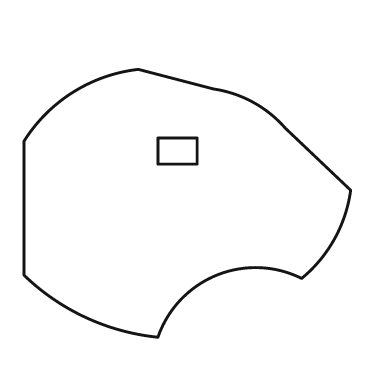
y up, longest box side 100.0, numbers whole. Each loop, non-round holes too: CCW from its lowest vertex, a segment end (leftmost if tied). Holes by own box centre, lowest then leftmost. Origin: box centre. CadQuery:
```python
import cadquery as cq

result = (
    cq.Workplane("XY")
    .moveTo(-9.0, -41.0)
    .threePointArc((9.0, -22.0), (35.0, -23.0))
    .threePointArc((45.0, -11.0), (50.0, 4.0))
    .lineTo(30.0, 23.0)
    .threePointArc((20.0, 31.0), (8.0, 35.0))
    .lineTo(-15.0, 41.0)
    .threePointArc((-35.0, 34.0), (-50.0, 19.0))
    .lineTo(-50.0, -22.0)
    .threePointArc((-31.0, -35.0), (-9.0, -41.0))
    .close()
    .moveTo(-9.0, 12.0)
    .lineTo(3.0, 12.0)
    .lineTo(3.0, 20.0)
    .lineTo(-9.0, 20.0)
    .close()
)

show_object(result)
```